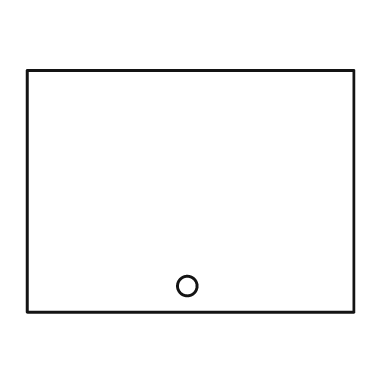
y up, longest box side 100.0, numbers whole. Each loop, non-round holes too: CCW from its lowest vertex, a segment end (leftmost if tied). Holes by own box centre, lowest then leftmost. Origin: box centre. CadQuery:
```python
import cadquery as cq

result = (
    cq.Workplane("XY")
    .moveTo(-50.0, -37.0)
    .lineTo(50.0, -37.0)
    .lineTo(50.0, 37.0)
    .lineTo(-50.0, 37.0)
    .close()
    .moveTo(-1.0, -29.0)
    .circle(3.0)
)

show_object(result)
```